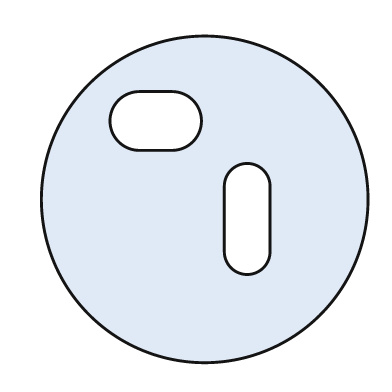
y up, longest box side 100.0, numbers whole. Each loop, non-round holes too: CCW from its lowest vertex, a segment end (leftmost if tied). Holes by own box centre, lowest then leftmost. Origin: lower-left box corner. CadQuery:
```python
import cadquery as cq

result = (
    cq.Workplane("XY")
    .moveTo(50.0, 50.0)
    .circle(50.0)
    .moveTo(56.0, 34.0)
    .threePointArc((63.0, 27.0), (70.0, 34.0))
    .lineTo(70.0, 54.0)
    .threePointArc((63.0, 61.0), (56.0, 54.0))
    .close()
    .moveTo(30.0, 65.0)
    .lineTo(40.0, 65.0)
    .threePointArc((49.0, 74.0), (40.0, 83.0))
    .lineTo(30.0, 83.0)
    .threePointArc((21.0, 74.0), (30.0, 65.0))
    .close()
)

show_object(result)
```